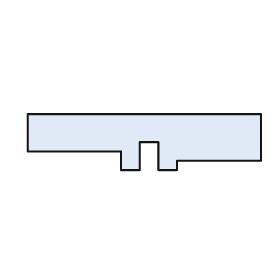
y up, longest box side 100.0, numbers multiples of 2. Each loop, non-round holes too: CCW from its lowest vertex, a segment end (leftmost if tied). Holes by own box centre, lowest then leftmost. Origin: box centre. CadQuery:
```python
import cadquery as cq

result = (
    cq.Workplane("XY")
    .moveTo(-10.0, -12.0)
    .lineTo(-2.0, -12.0)
    .lineTo(-2.0, 0.0)
    .lineTo(6.0, 0.0)
    .lineTo(6.0, -12.0)
    .lineTo(14.0, -12.0)
    .lineTo(14.0, -8.0)
    .lineTo(50.0, -8.0)
    .lineTo(50.0, 12.0)
    .lineTo(-50.0, 12.0)
    .lineTo(-50.0, -4.0)
    .lineTo(-10.0, -4.0)
    .close()
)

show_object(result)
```